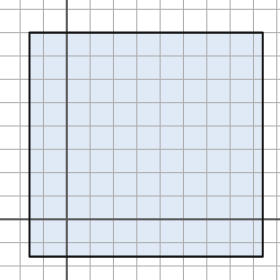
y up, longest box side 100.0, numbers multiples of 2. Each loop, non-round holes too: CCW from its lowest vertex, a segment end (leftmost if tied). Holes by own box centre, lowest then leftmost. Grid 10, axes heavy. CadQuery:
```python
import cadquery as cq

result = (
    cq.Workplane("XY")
    .moveTo(-16.0, -16.0)
    .lineTo(84.0, -16.0)
    .lineTo(84.0, 80.0)
    .lineTo(-16.0, 80.0)
    .close()
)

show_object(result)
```